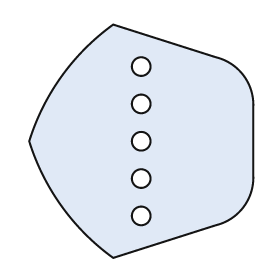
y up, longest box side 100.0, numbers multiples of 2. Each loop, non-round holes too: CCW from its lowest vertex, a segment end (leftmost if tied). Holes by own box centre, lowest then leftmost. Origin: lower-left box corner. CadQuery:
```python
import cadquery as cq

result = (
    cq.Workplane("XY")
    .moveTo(36.0, 0.0)
    .lineTo(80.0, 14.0)
    .threePointArc((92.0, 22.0), (96.0, 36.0))
    .lineTo(96.0, 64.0)
    .threePointArc((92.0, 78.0), (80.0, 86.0))
    .lineTo(36.0, 100.0)
    .threePointArc((14.0, 78.0), (0.0, 50.0))
    .threePointArc((14.0, 22.0), (36.0, 0.0))
    .close()
    .moveTo(48.0, 18.0)
    .circle(4.0)
    .moveTo(48.0, 34.0)
    .circle(4.0)
    .moveTo(48.0, 50.0)
    .circle(4.0)
    .moveTo(48.0, 66.0)
    .circle(4.0)
    .moveTo(48.0, 82.0)
    .circle(4.0)
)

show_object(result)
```